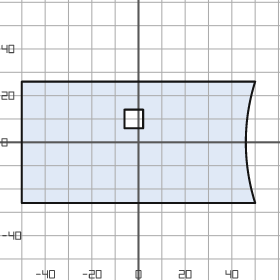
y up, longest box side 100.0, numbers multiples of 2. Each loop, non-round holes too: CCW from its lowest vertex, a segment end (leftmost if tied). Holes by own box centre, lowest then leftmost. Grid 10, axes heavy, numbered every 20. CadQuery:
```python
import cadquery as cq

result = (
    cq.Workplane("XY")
    .moveTo(-50.0, -26.0)
    .lineTo(50.0, -26.0)
    .threePointArc((46.0, 0.0), (50.0, 26.0))
    .lineTo(-50.0, 26.0)
    .close()
    .moveTo(-6.0, 6.0)
    .lineTo(2.0, 6.0)
    .lineTo(2.0, 14.0)
    .lineTo(-6.0, 14.0)
    .close()
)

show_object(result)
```